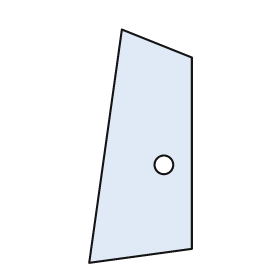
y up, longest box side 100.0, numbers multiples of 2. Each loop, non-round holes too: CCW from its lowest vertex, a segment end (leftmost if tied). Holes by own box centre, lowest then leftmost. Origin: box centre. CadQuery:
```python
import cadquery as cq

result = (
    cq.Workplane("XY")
    .moveTo(-22.0, -50.0)
    .lineTo(22.0, -44.0)
    .lineTo(22.0, 38.0)
    .lineTo(-8.0, 50.0)
    .close()
    .moveTo(10.0, -8.0)
    .circle(4.0)
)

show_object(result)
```